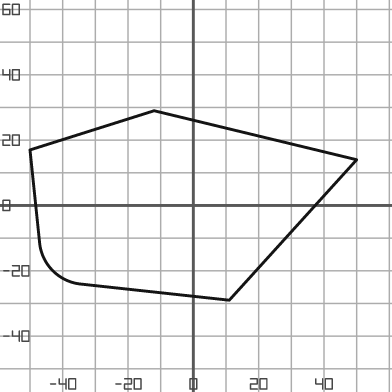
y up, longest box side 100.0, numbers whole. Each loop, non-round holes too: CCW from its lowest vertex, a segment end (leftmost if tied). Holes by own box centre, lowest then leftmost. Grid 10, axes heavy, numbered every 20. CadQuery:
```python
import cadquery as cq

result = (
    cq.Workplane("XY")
    .moveTo(11.0, -29.0)
    .lineTo(50.0, 14.0)
    .lineTo(-12.0, 29.0)
    .lineTo(-50.0, 17.0)
    .lineTo(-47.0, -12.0)
    .threePointArc((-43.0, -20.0), (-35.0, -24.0))
    .close()
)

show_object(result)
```